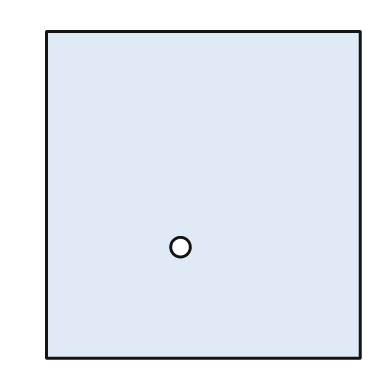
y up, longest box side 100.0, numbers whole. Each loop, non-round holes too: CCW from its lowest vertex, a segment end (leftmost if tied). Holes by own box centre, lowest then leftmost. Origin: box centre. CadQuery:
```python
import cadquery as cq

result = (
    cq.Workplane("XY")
    .moveTo(-48.0, -50.0)
    .lineTo(48.0, -50.0)
    .lineTo(48.0, 50.0)
    .lineTo(-48.0, 50.0)
    .close()
    .moveTo(-7.0, -16.0)
    .circle(3.0)
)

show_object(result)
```